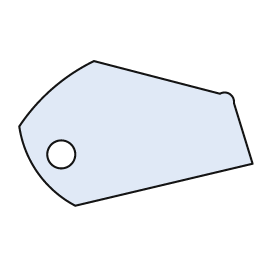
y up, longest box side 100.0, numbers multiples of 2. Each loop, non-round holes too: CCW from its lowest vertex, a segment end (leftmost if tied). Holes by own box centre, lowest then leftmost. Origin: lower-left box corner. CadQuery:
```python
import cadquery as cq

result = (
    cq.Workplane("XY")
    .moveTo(24.0, 0.0)
    .lineTo(100.0, 18.0)
    .lineTo(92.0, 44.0)
    .threePointArc((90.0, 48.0), (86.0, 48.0))
    .lineTo(32.0, 62.0)
    .threePointArc((14.0, 50.0), (0.0, 34.0))
    .threePointArc((8.0, 14.0), (24.0, 0.0))
    .close()
    .moveTo(18.0, 22.0)
    .circle(6.0)
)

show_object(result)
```